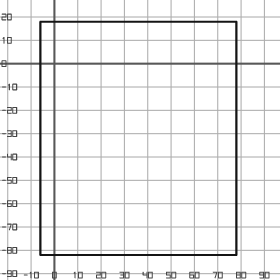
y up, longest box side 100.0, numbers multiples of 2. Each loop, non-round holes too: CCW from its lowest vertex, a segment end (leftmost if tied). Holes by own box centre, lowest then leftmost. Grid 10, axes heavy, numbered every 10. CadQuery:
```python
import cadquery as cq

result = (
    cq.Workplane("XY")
    .moveTo(-6.0, -82.0)
    .lineTo(78.0, -82.0)
    .lineTo(78.0, 18.0)
    .lineTo(-6.0, 18.0)
    .close()
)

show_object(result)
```